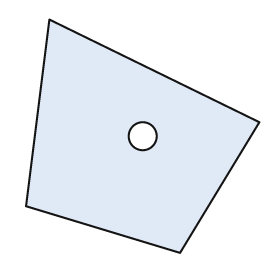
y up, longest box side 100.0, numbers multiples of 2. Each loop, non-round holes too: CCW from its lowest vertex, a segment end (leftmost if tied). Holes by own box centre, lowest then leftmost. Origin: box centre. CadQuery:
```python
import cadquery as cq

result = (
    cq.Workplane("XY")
    .moveTo(16.0, -50.0)
    .lineTo(50.0, 6.0)
    .lineTo(-40.0, 50.0)
    .lineTo(-50.0, -30.0)
    .close()
    .moveTo(0.0, 0.0)
    .circle(6.0)
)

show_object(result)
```